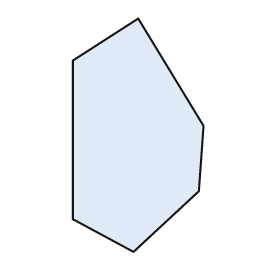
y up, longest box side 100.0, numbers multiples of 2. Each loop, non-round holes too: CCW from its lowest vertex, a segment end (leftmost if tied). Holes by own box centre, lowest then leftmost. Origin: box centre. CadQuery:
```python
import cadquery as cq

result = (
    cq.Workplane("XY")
    .moveTo(-2.0, -50.0)
    .lineTo(26.0, -24.0)
    .lineTo(28.0, 4.0)
    .lineTo(0.0, 50.0)
    .lineTo(-28.0, 32.0)
    .lineTo(-28.0, -36.0)
    .close()
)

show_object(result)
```